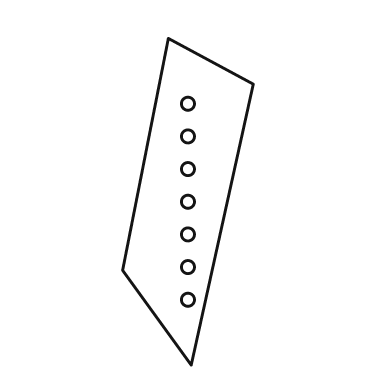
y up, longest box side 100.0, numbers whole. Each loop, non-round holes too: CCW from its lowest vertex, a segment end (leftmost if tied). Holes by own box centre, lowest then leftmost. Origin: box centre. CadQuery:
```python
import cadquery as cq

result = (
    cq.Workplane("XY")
    .moveTo(1.0, -50.0)
    .lineTo(20.0, 36.0)
    .lineTo(-6.0, 50.0)
    .lineTo(-20.0, -21.0)
    .close()
    .moveTo(0.0, -30.0)
    .circle(2.0)
    .moveTo(0.0, -20.0)
    .circle(2.0)
    .moveTo(0.0, -10.0)
    .circle(2.0)
    .moveTo(0.0, 0.0)
    .circle(2.0)
    .moveTo(0.0, 10.0)
    .circle(2.0)
    .moveTo(0.0, 20.0)
    .circle(2.0)
    .moveTo(0.0, 30.0)
    .circle(2.0)
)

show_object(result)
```